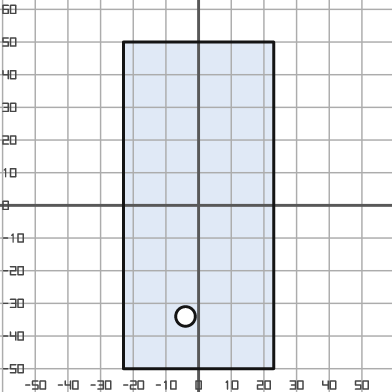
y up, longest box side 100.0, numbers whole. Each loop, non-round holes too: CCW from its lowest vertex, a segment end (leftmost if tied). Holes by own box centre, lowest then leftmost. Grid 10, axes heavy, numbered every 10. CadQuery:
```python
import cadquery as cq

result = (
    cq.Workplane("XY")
    .moveTo(-23.0, -50.0)
    .lineTo(23.0, -50.0)
    .lineTo(23.0, 50.0)
    .lineTo(-23.0, 50.0)
    .close()
    .moveTo(-4.0, -34.0)
    .circle(3.0)
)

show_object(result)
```